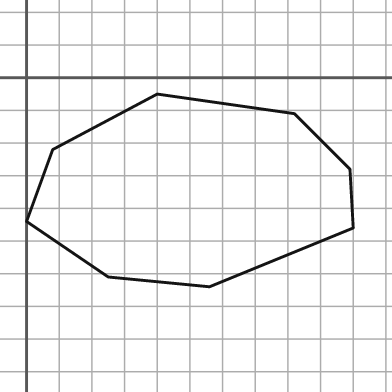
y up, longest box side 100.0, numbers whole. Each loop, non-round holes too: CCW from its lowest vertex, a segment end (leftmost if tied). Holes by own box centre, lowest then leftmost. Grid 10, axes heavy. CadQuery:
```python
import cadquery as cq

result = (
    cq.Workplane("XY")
    .moveTo(56.0, -64.0)
    .lineTo(100.0, -46.0)
    .lineTo(99.0, -28.0)
    .lineTo(82.0, -11.0)
    .lineTo(40.0, -5.0)
    .lineTo(8.0, -22.0)
    .lineTo(0.0, -44.0)
    .lineTo(25.0, -61.0)
    .close()
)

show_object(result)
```